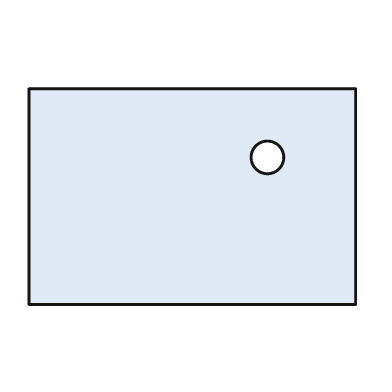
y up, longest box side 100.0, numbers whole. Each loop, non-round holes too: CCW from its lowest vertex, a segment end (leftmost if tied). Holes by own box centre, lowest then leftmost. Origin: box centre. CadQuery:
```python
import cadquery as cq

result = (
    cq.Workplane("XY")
    .moveTo(-50.0, -33.0)
    .lineTo(50.0, -33.0)
    .lineTo(50.0, 33.0)
    .lineTo(-50.0, 33.0)
    .close()
    .moveTo(23.0, 12.0)
    .circle(5.0)
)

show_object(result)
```